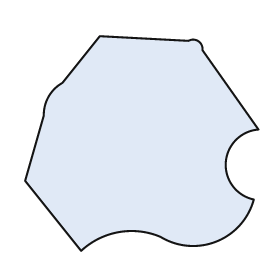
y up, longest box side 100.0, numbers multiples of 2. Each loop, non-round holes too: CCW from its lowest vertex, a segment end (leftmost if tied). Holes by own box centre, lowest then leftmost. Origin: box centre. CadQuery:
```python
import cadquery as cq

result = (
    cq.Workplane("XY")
    .moveTo(-26.0, -46.0)
    .threePointArc((-10.0, -38.0), (8.0, -40.0))
    .threePointArc((32.0, -42.0), (48.0, -24.0))
    .threePointArc((36.0, -8.0), (50.0, 6.0))
    .lineTo(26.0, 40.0)
    .threePointArc((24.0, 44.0), (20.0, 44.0))
    .lineTo(-18.0, 46.0)
    .lineTo(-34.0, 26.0)
    .threePointArc((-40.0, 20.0), (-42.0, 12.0))
    .lineTo(-50.0, -16.0)
    .close()
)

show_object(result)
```